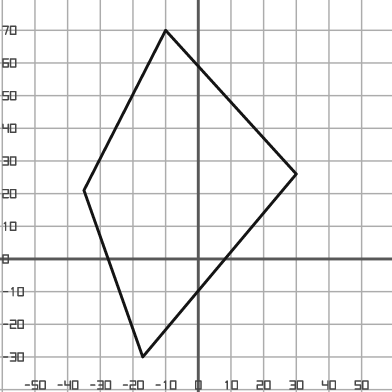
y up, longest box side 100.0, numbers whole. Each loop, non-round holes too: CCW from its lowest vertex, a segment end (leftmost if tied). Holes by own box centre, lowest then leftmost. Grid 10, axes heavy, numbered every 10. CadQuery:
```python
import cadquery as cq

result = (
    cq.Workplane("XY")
    .moveTo(-17.0, -30.0)
    .lineTo(30.0, 26.0)
    .lineTo(-10.0, 70.0)
    .lineTo(-35.0, 21.0)
    .close()
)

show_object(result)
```